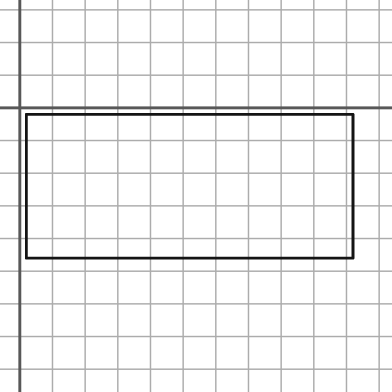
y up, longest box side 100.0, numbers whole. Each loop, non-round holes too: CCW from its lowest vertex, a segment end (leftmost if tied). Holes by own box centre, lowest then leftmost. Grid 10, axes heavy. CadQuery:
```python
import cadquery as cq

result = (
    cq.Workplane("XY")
    .moveTo(2.0, -46.0)
    .lineTo(102.0, -46.0)
    .lineTo(102.0, -2.0)
    .lineTo(2.0, -2.0)
    .close()
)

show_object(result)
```